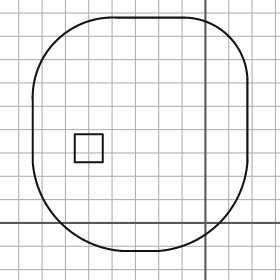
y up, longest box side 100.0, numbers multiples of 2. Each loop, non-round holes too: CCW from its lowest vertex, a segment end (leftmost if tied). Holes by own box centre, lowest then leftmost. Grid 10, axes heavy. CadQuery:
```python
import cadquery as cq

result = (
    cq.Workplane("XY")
    .moveTo(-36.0, -12.0)
    .lineTo(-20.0, -12.0)
    .threePointArc((6.0, 0.0), (18.0, 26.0))
    .lineTo(18.0, 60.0)
    .threePointArc((10.0, 80.0), (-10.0, 88.0))
    .lineTo(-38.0, 88.0)
    .threePointArc((-64.0, 78.0), (-74.0, 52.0))
    .lineTo(-74.0, 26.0)
    .threePointArc((-62.0, 0.0), (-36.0, -12.0))
    .close()
    .moveTo(-56.0, 26.0)
    .lineTo(-44.0, 26.0)
    .lineTo(-44.0, 38.0)
    .lineTo(-56.0, 38.0)
    .close()
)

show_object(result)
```